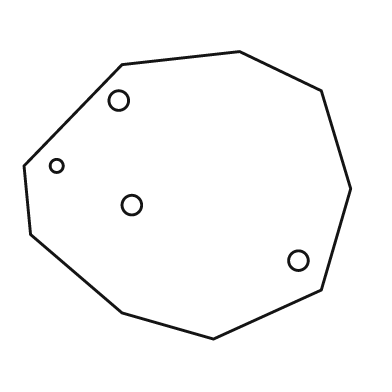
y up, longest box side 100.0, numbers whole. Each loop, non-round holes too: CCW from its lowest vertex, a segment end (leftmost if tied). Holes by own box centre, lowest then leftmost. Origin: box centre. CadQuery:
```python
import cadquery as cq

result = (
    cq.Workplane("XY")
    .moveTo(8.0, -44.0)
    .lineTo(41.0, -29.0)
    .lineTo(50.0, 2.0)
    .lineTo(41.0, 32.0)
    .lineTo(16.0, 44.0)
    .lineTo(-20.0, 40.0)
    .lineTo(-50.0, 9.0)
    .lineTo(-48.0, -12.0)
    .lineTo(-20.0, -36.0)
    .close()
    .moveTo(34.0, -20.0)
    .circle(3.0)
    .moveTo(-17.0, -3.0)
    .circle(3.0)
    .moveTo(-40.0, 9.0)
    .circle(2.0)
    .moveTo(-21.0, 29.0)
    .circle(3.0)
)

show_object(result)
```